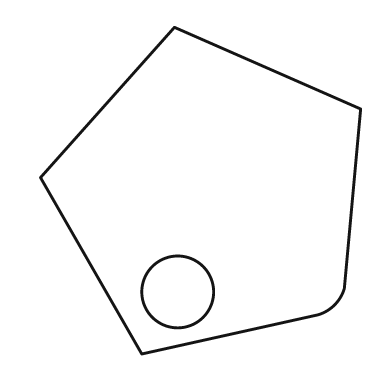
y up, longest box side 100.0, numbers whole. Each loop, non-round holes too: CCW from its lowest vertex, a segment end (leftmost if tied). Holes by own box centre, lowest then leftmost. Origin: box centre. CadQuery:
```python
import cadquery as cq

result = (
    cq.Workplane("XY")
    .moveTo(-18.0, -50.0)
    .lineTo(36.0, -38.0)
    .threePointArc((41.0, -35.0), (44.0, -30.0))
    .lineTo(49.0, 25.0)
    .lineTo(-8.0, 50.0)
    .lineTo(-49.0, 4.0)
    .close()
    .moveTo(-7.0, -31.0)
    .circle(11.0)
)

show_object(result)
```